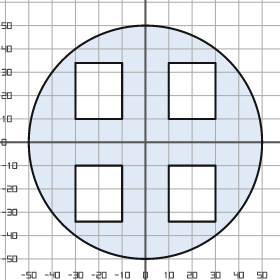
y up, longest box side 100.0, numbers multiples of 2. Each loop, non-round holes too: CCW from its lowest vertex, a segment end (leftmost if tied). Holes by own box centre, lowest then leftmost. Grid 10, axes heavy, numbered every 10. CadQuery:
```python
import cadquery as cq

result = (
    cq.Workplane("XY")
    .moveTo(0.0, 0.0)
    .circle(50.0)
    .moveTo(-30.0, -34.0)
    .lineTo(-10.0, -34.0)
    .lineTo(-10.0, -10.0)
    .lineTo(-30.0, -10.0)
    .close()
    .moveTo(10.0, -34.0)
    .lineTo(30.0, -34.0)
    .lineTo(30.0, -10.0)
    .lineTo(10.0, -10.0)
    .close()
    .moveTo(-30.0, 10.0)
    .lineTo(-10.0, 10.0)
    .lineTo(-10.0, 34.0)
    .lineTo(-30.0, 34.0)
    .close()
    .moveTo(10.0, 10.0)
    .lineTo(30.0, 10.0)
    .lineTo(30.0, 34.0)
    .lineTo(10.0, 34.0)
    .close()
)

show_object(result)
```